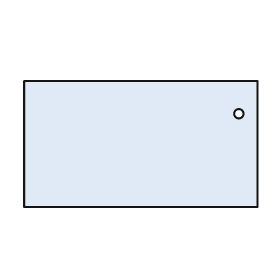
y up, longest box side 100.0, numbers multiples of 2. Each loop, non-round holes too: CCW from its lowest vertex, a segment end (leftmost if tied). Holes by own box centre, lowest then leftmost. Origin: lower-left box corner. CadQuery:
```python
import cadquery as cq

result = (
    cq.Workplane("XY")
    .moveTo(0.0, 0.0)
    .lineTo(100.0, 0.0)
    .lineTo(100.0, 54.0)
    .lineTo(0.0, 54.0)
    .close()
    .moveTo(92.0, 40.0)
    .circle(2.0)
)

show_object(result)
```